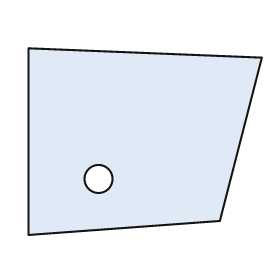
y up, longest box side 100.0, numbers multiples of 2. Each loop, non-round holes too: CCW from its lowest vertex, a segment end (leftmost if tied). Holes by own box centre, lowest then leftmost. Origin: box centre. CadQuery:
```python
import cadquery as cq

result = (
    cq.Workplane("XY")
    .moveTo(-50.0, -40.0)
    .lineTo(32.0, -34.0)
    .lineTo(50.0, 36.0)
    .lineTo(-50.0, 40.0)
    .close()
    .moveTo(-20.0, -16.0)
    .circle(6.0)
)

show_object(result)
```